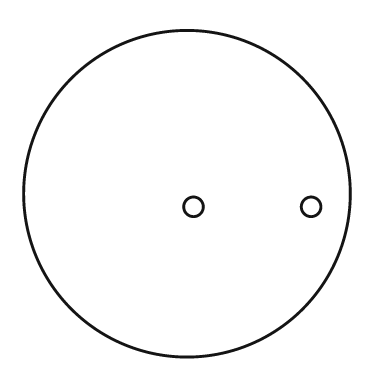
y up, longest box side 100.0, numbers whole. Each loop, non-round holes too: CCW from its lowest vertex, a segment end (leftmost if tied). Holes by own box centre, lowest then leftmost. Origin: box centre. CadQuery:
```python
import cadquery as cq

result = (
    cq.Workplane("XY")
    .moveTo(0.0, 0.0)
    .circle(50.0)
    .moveTo(2.0, -4.0)
    .circle(3.0)
    .moveTo(38.0, -4.0)
    .circle(3.0)
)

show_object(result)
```